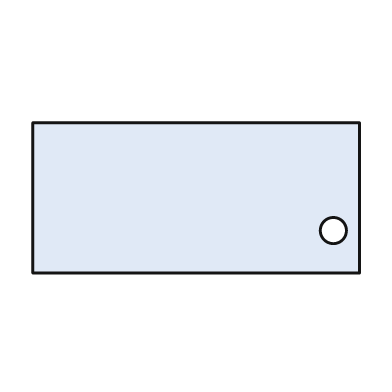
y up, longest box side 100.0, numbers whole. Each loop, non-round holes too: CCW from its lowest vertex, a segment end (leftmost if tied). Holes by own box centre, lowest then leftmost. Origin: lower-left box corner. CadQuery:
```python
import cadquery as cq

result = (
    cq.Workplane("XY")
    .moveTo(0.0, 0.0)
    .lineTo(100.0, 0.0)
    .lineTo(100.0, 46.0)
    .lineTo(0.0, 46.0)
    .close()
    .moveTo(92.0, 13.0)
    .circle(4.0)
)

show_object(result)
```